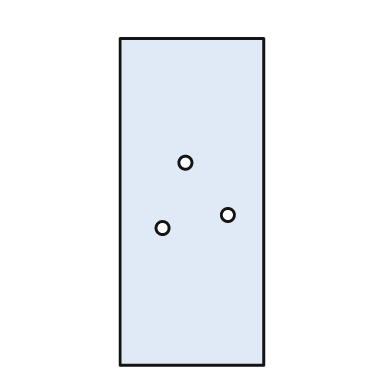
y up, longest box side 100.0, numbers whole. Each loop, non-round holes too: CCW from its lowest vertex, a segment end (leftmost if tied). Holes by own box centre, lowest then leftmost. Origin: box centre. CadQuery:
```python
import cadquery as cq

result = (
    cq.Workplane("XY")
    .moveTo(-22.0, -50.0)
    .lineTo(22.0, -50.0)
    .lineTo(22.0, 50.0)
    .lineTo(-22.0, 50.0)
    .close()
    .moveTo(-9.0, -8.0)
    .circle(2.0)
    .moveTo(11.0, -4.0)
    .circle(2.0)
    .moveTo(-2.0, 12.0)
    .circle(2.0)
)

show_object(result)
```